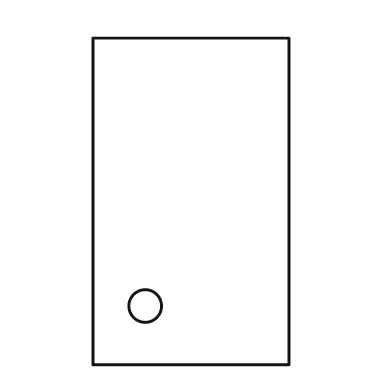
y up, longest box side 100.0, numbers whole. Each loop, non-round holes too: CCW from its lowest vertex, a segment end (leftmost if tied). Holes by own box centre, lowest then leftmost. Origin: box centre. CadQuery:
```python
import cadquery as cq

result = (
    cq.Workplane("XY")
    .moveTo(-30.0, -50.0)
    .lineTo(30.0, -50.0)
    .lineTo(30.0, 50.0)
    .lineTo(-30.0, 50.0)
    .close()
    .moveTo(-14.0, -32.0)
    .circle(5.0)
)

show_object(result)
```